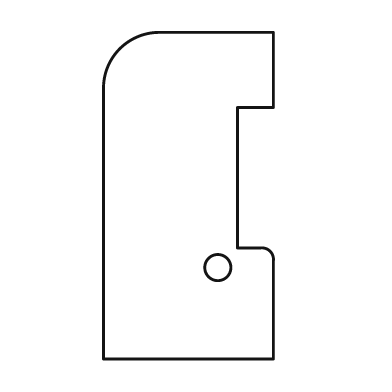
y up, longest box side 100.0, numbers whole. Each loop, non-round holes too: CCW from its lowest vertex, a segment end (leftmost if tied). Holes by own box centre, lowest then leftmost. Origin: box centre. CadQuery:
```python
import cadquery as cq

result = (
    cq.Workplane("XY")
    .moveTo(-26.0, -50.0)
    .lineTo(26.0, -50.0)
    .lineTo(26.0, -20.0)
    .threePointArc((25.0, -17.0), (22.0, -16.0))
    .lineTo(15.0, -16.0)
    .lineTo(15.0, 27.0)
    .lineTo(26.0, 27.0)
    .lineTo(26.0, 50.0)
    .lineTo(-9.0, 50.0)
    .threePointArc((-21.0, 45.0), (-26.0, 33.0))
    .close()
    .moveTo(9.0, -22.0)
    .circle(4.0)
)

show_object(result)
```